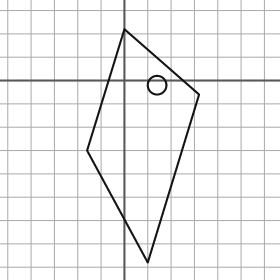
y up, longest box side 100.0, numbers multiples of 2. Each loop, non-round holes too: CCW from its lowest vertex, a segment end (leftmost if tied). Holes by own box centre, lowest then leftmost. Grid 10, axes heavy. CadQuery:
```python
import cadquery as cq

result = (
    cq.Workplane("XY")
    .moveTo(10.0, -78.0)
    .lineTo(32.0, -6.0)
    .lineTo(0.0, 22.0)
    .lineTo(-16.0, -30.0)
    .close()
    .moveTo(14.0, -2.0)
    .circle(4.0)
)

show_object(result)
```